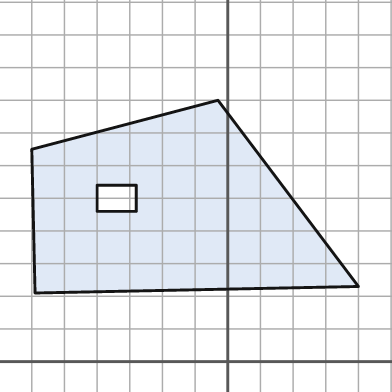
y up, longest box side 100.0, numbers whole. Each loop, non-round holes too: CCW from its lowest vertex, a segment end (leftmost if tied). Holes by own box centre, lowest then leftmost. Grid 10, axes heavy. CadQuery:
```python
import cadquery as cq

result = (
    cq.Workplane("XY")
    .moveTo(-59.0, 21.0)
    .lineTo(40.0, 23.0)
    .lineTo(-3.0, 80.0)
    .lineTo(-60.0, 65.0)
    .close()
    .moveTo(-40.0, 46.0)
    .lineTo(-28.0, 46.0)
    .lineTo(-28.0, 54.0)
    .lineTo(-40.0, 54.0)
    .close()
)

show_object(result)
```